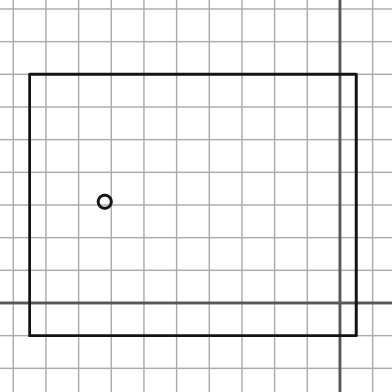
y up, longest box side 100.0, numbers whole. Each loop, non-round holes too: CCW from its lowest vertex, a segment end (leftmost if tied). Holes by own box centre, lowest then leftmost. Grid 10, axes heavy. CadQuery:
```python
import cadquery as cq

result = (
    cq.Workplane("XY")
    .moveTo(-95.0, -10.0)
    .lineTo(5.0, -10.0)
    .lineTo(5.0, 70.0)
    .lineTo(-95.0, 70.0)
    .close()
    .moveTo(-72.0, 31.0)
    .circle(2.0)
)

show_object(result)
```